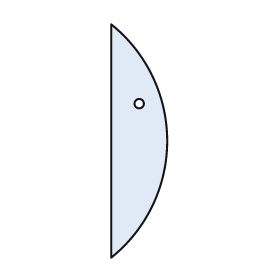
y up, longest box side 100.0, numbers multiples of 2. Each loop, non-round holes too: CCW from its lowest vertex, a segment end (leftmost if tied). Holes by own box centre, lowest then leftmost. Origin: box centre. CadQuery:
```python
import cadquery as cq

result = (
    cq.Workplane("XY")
    .moveTo(-12.0, -50.0)
    .threePointArc((12.0, 0.0), (-12.0, 50.0))
    .close()
    .moveTo(0.0, 16.0)
    .circle(2.0)
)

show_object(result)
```